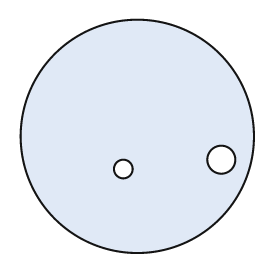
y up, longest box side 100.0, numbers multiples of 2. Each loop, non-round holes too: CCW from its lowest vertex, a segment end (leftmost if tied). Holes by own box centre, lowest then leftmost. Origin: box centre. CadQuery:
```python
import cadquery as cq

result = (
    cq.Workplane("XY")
    .moveTo(0.0, 0.0)
    .circle(50.0)
    .moveTo(-6.0, -14.0)
    .circle(4.0)
    .moveTo(36.0, -10.0)
    .circle(6.0)
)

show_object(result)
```